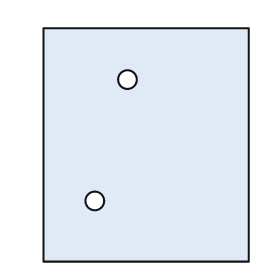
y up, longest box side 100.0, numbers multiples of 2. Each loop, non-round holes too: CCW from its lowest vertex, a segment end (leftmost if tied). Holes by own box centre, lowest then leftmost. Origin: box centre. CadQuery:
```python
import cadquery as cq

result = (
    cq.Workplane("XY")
    .moveTo(-44.0, -50.0)
    .lineTo(44.0, -50.0)
    .lineTo(44.0, 50.0)
    .lineTo(-44.0, 50.0)
    .close()
    .moveTo(-22.0, -24.0)
    .circle(4.0)
    .moveTo(-8.0, 28.0)
    .circle(4.0)
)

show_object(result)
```